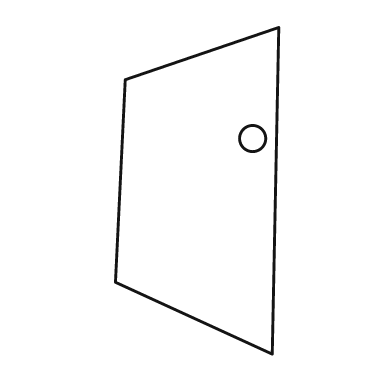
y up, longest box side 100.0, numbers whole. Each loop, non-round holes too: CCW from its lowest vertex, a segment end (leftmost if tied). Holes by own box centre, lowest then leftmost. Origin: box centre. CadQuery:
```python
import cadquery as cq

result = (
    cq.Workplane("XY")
    .moveTo(23.0, -50.0)
    .lineTo(25.0, 50.0)
    .lineTo(-22.0, 34.0)
    .lineTo(-25.0, -28.0)
    .close()
    .moveTo(17.0, 16.0)
    .circle(4.0)
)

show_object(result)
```